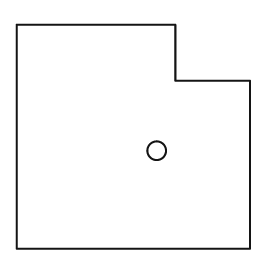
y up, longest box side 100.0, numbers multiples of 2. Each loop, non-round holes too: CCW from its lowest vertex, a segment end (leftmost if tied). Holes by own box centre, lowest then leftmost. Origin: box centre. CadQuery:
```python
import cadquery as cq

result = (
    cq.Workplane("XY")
    .moveTo(-50.0, -48.0)
    .lineTo(50.0, -48.0)
    .lineTo(50.0, 24.0)
    .lineTo(18.0, 24.0)
    .lineTo(18.0, 48.0)
    .lineTo(-50.0, 48.0)
    .close()
    .moveTo(10.0, -6.0)
    .circle(4.0)
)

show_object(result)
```